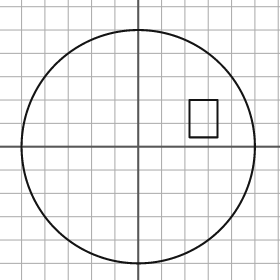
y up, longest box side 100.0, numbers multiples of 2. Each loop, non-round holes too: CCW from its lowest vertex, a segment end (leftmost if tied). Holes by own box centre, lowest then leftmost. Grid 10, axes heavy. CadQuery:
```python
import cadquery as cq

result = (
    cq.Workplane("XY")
    .moveTo(0.0, 0.0)
    .circle(50.0)
    .moveTo(22.0, 4.0)
    .lineTo(34.0, 4.0)
    .lineTo(34.0, 20.0)
    .lineTo(22.0, 20.0)
    .close()
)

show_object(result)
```